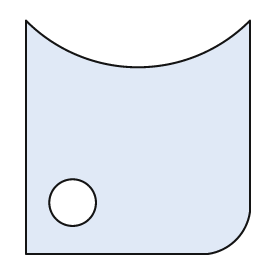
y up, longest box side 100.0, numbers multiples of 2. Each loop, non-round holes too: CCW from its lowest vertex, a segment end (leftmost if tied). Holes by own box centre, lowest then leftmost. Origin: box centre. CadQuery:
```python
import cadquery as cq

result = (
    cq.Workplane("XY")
    .moveTo(-48.0, -50.0)
    .lineTo(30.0, -50.0)
    .threePointArc((42.0, -44.0), (48.0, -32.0))
    .lineTo(48.0, 50.0)
    .threePointArc((0.0, 30.0), (-48.0, 50.0))
    .close()
    .moveTo(-28.0, -28.0)
    .circle(10.0)
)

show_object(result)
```